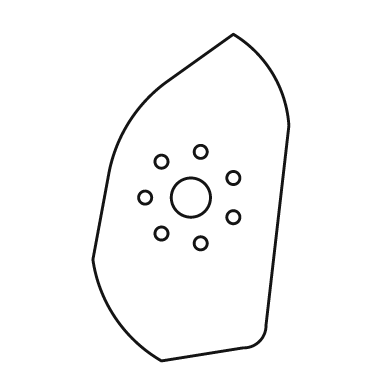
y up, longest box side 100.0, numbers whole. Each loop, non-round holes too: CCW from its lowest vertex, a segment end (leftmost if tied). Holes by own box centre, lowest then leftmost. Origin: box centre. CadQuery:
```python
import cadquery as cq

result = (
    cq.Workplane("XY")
    .moveTo(-9.0, -50.0)
    .lineTo(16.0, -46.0)
    .threePointArc((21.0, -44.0), (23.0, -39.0))
    .lineTo(30.0, 22.0)
    .threePointArc((25.0, 38.0), (13.0, 50.0))
    .lineTo(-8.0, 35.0)
    .threePointArc((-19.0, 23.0), (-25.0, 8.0))
    .lineTo(-30.0, -19.0)
    .threePointArc((-23.0, -37.0), (-9.0, -50.0))
    .close()
    .moveTo(3.0, -14.0)
    .circle(2.0)
    .moveTo(-9.0, -11.0)
    .circle(2.0)
    .moveTo(13.0, -6.0)
    .circle(2.0)
    .moveTo(-14.0, 0.0)
    .circle(2.0)
    .moveTo(0.0, 0.0)
    .circle(6.0)
    .moveTo(13.0, 6.0)
    .circle(2.0)
    .moveTo(-9.0, 11.0)
    .circle(2.0)
    .moveTo(3.0, 14.0)
    .circle(2.0)
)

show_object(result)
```